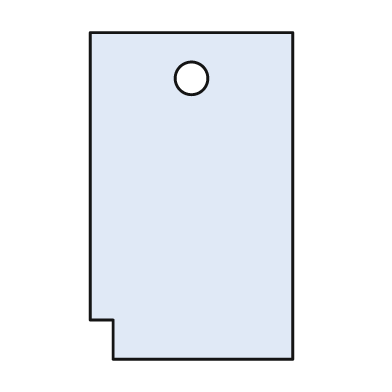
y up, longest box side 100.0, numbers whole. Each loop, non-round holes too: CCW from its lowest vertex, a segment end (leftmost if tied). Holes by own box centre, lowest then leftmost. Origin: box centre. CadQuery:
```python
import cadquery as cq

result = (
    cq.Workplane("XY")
    .moveTo(-24.0, -50.0)
    .lineTo(31.0, -50.0)
    .lineTo(31.0, 50.0)
    .lineTo(-31.0, 50.0)
    .lineTo(-31.0, -38.0)
    .lineTo(-24.0, -38.0)
    .close()
    .moveTo(0.0, 36.0)
    .circle(5.0)
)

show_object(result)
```